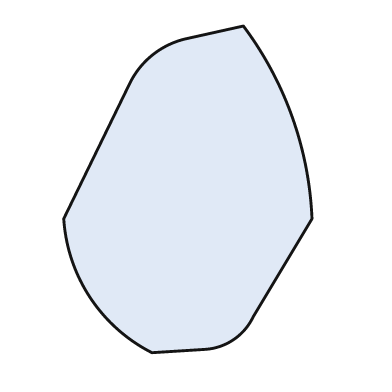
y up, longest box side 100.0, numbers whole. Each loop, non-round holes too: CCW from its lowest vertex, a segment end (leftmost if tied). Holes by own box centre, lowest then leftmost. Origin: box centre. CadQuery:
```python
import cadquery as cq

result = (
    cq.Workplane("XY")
    .moveTo(-11.0, -50.0)
    .lineTo(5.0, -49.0)
    .threePointArc((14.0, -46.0), (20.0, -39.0))
    .lineTo(38.0, -9.0)
    .threePointArc((32.0, 22.0), (17.0, 50.0))
    .lineTo(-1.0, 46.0)
    .threePointArc((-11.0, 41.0), (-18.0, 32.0))
    .lineTo(-38.0, -9.0)
    .threePointArc((-30.0, -33.0), (-11.0, -50.0))
    .close()
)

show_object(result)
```